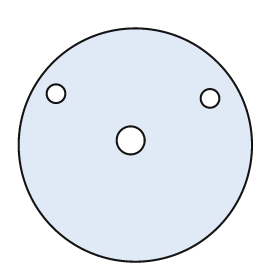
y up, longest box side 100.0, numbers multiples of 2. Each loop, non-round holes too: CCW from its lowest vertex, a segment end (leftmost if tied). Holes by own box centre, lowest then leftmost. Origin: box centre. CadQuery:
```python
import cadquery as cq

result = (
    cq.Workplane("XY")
    .moveTo(0.0, 0.0)
    .circle(50.0)
    .moveTo(-2.0, 2.0)
    .circle(6.0)
    .moveTo(32.0, 20.0)
    .circle(4.0)
    .moveTo(-34.0, 22.0)
    .circle(4.0)
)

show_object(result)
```